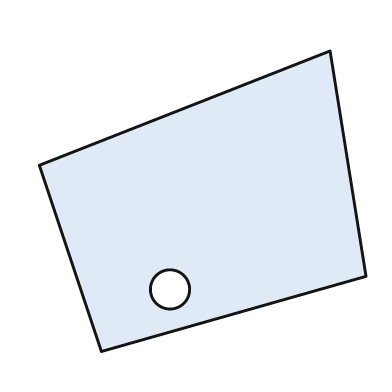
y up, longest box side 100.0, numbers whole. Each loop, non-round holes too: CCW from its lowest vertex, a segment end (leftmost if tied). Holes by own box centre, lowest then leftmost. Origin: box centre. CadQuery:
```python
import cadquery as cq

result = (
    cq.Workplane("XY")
    .moveTo(-31.0, -46.0)
    .lineTo(50.0, -23.0)
    .lineTo(39.0, 46.0)
    .lineTo(-50.0, 11.0)
    .close()
    .moveTo(-10.0, -27.0)
    .circle(6.0)
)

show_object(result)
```